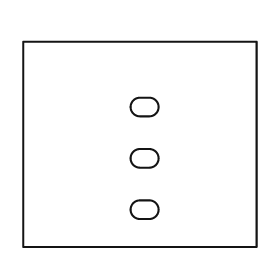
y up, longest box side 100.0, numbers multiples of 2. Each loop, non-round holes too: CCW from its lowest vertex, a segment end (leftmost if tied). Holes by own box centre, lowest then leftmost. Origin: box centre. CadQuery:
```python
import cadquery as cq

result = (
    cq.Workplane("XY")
    .moveTo(-50.0, -44.0)
    .lineTo(50.0, -44.0)
    .lineTo(50.0, 44.0)
    .lineTo(-50.0, 44.0)
    .close()
    .moveTo(0.0, -32.0)
    .lineTo(4.0, -32.0)
    .threePointArc((8.0, -28.0), (4.0, -24.0))
    .lineTo(0.0, -24.0)
    .threePointArc((-4.0, -28.0), (0.0, -32.0))
    .close()
    .moveTo(0.0, -10.0)
    .lineTo(4.0, -10.0)
    .threePointArc((8.0, -6.0), (4.0, -2.0))
    .lineTo(0.0, -2.0)
    .threePointArc((-4.0, -6.0), (0.0, -10.0))
    .close()
    .moveTo(0.0, 12.0)
    .lineTo(4.0, 12.0)
    .threePointArc((8.0, 16.0), (4.0, 20.0))
    .lineTo(0.0, 20.0)
    .threePointArc((-4.0, 16.0), (0.0, 12.0))
    .close()
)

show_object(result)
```